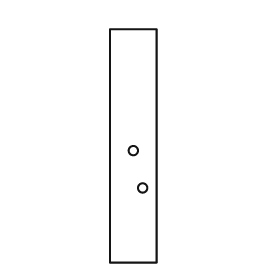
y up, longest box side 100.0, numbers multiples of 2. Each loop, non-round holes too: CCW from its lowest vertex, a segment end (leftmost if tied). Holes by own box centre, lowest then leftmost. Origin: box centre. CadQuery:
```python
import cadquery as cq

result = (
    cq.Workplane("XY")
    .moveTo(-10.0, -50.0)
    .lineTo(10.0, -50.0)
    .lineTo(10.0, 50.0)
    .lineTo(-10.0, 50.0)
    .close()
    .moveTo(4.0, -18.0)
    .circle(2.0)
    .moveTo(0.0, -2.0)
    .circle(2.0)
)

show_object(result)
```